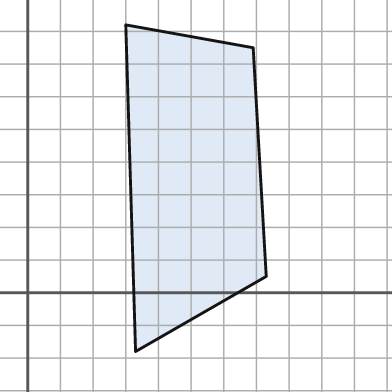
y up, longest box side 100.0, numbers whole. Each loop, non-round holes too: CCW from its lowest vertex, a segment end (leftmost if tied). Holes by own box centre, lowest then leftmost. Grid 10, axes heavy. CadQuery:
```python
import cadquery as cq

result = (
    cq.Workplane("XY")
    .moveTo(33.0, -18.0)
    .lineTo(73.0, 5.0)
    .lineTo(69.0, 75.0)
    .lineTo(30.0, 82.0)
    .close()
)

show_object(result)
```